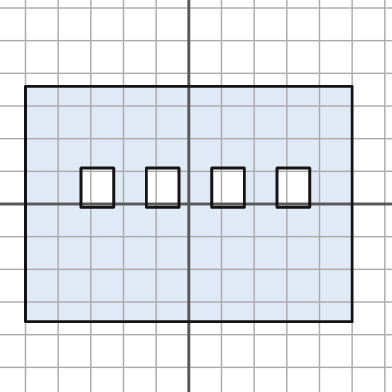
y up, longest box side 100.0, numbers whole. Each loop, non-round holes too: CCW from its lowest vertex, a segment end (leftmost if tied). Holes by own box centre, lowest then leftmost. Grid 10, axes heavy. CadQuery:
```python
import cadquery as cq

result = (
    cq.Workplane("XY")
    .moveTo(-50.0, -36.0)
    .lineTo(50.0, -36.0)
    .lineTo(50.0, 36.0)
    .lineTo(-50.0, 36.0)
    .close()
    .moveTo(-33.0, -1.0)
    .lineTo(-23.0, -1.0)
    .lineTo(-23.0, 11.0)
    .lineTo(-33.0, 11.0)
    .close()
    .moveTo(-13.0, -1.0)
    .lineTo(-3.0, -1.0)
    .lineTo(-3.0, 11.0)
    .lineTo(-13.0, 11.0)
    .close()
    .moveTo(7.0, -1.0)
    .lineTo(17.0, -1.0)
    .lineTo(17.0, 11.0)
    .lineTo(7.0, 11.0)
    .close()
    .moveTo(27.0, -1.0)
    .lineTo(37.0, -1.0)
    .lineTo(37.0, 11.0)
    .lineTo(27.0, 11.0)
    .close()
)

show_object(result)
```